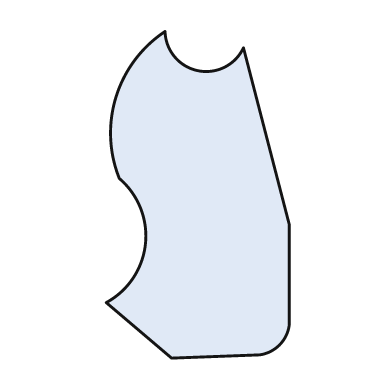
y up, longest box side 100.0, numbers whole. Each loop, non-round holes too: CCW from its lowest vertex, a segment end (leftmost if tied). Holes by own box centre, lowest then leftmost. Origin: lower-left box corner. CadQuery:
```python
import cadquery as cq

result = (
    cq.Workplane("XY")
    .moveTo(20.0, 0.0)
    .lineTo(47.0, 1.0)
    .threePointArc((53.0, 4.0), (56.0, 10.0))
    .lineTo(56.0, 41.0)
    .lineTo(42.0, 95.0)
    .threePointArc((28.0, 88.0), (18.0, 100.0))
    .threePointArc((3.0, 80.0), (4.0, 55.0))
    .threePointArc((12.0, 35.0), (0.0, 17.0))
    .close()
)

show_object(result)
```